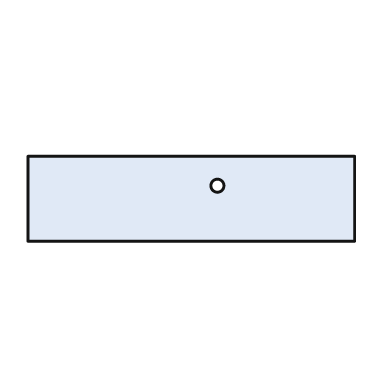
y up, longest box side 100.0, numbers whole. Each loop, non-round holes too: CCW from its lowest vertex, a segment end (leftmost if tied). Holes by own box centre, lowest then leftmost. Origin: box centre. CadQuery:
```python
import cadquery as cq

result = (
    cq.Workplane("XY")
    .moveTo(-50.0, -13.0)
    .lineTo(50.0, -13.0)
    .lineTo(50.0, 13.0)
    .lineTo(-50.0, 13.0)
    .close()
    .moveTo(8.0, 4.0)
    .circle(2.0)
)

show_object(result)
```